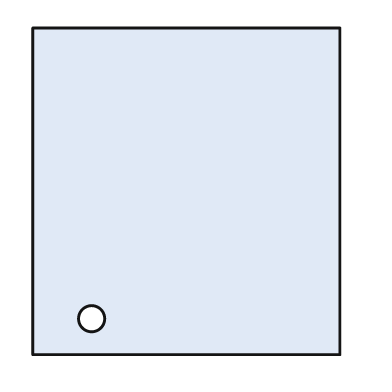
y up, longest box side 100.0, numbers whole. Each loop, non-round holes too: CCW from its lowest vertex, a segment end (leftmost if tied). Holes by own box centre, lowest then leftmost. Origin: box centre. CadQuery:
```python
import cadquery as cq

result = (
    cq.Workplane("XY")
    .moveTo(-47.0, -50.0)
    .lineTo(47.0, -50.0)
    .lineTo(47.0, 50.0)
    .lineTo(-47.0, 50.0)
    .close()
    .moveTo(-29.0, -39.0)
    .circle(4.0)
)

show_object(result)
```